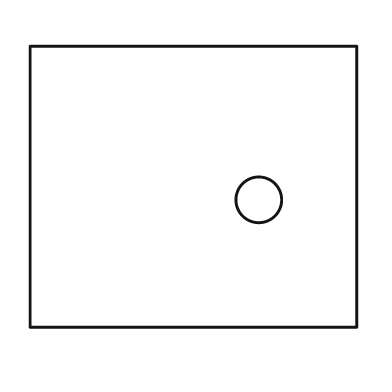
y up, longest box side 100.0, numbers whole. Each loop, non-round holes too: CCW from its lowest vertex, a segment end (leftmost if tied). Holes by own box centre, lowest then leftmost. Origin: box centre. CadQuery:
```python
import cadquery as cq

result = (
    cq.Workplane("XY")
    .moveTo(-50.0, -43.0)
    .lineTo(50.0, -43.0)
    .lineTo(50.0, 43.0)
    .lineTo(-50.0, 43.0)
    .close()
    .moveTo(20.0, -4.0)
    .circle(7.0)
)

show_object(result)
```